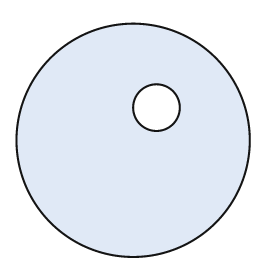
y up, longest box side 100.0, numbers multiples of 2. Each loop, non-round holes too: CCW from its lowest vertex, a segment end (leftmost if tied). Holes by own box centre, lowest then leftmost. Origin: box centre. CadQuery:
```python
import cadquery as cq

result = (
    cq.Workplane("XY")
    .moveTo(0.0, 0.0)
    .circle(50.0)
    .moveTo(10.0, 14.0)
    .circle(10.0)
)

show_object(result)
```